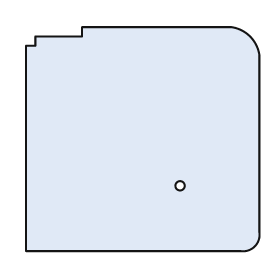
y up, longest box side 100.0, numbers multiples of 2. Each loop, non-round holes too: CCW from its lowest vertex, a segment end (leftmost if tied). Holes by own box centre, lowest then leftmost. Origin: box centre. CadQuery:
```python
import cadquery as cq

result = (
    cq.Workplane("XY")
    .moveTo(-50.0, -48.0)
    .lineTo(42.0, -48.0)
    .threePointArc((48.0, -46.0), (50.0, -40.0))
    .lineTo(50.0, 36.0)
    .threePointArc((46.0, 44.0), (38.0, 48.0))
    .lineTo(-26.0, 48.0)
    .lineTo(-26.0, 44.0)
    .lineTo(-46.0, 44.0)
    .lineTo(-46.0, 40.0)
    .lineTo(-50.0, 40.0)
    .close()
    .moveTo(16.0, -20.0)
    .circle(2.0)
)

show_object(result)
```